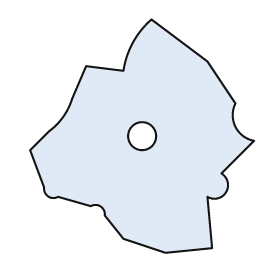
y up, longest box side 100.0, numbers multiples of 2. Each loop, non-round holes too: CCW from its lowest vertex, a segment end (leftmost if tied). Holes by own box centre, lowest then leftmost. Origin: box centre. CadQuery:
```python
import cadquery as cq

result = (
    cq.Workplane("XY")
    .moveTo(10.0, -50.0)
    .lineTo(30.0, -48.0)
    .lineTo(28.0, -26.0)
    .threePointArc((36.0, -24.0), (34.0, -16.0))
    .lineTo(48.0, -2.0)
    .threePointArc((40.0, 4.0), (40.0, 14.0))
    .lineTo(28.0, 32.0)
    .lineTo(4.0, 50.0)
    .threePointArc((-4.0, 40.0), (-8.0, 28.0))
    .lineTo(-24.0, 30.0)
    .lineTo(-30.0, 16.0)
    .threePointArc((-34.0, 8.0), (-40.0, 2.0))
    .lineTo(-48.0, -6.0)
    .lineTo(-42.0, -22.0)
    .threePointArc((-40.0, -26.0), (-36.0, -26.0))
    .lineTo(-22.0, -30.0)
    .threePointArc((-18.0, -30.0), (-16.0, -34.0))
    .lineTo(-8.0, -44.0)
    .close()
    .moveTo(0.0, 0.0)
    .circle(6.0)
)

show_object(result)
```